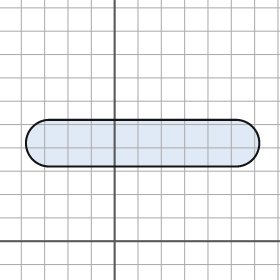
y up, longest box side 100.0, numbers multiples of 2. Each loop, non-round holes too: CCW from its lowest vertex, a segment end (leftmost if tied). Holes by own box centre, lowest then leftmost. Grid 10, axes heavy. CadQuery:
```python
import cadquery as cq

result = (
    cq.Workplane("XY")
    .moveTo(-28.0, 32.0)
    .lineTo(52.0, 32.0)
    .threePointArc((62.0, 42.0), (52.0, 52.0))
    .lineTo(-28.0, 52.0)
    .threePointArc((-38.0, 42.0), (-28.0, 32.0))
    .close()
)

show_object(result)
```